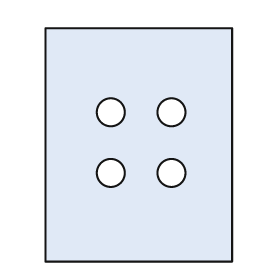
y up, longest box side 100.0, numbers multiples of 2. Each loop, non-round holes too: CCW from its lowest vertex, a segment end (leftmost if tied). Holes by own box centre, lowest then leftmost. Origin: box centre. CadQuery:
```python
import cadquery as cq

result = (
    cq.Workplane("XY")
    .moveTo(-40.0, -50.0)
    .lineTo(40.0, -50.0)
    .lineTo(40.0, 50.0)
    .lineTo(-40.0, 50.0)
    .close()
    .moveTo(-12.0, -12.0)
    .circle(6.0)
    .moveTo(14.0, -12.0)
    .circle(6.0)
    .moveTo(-12.0, 14.0)
    .circle(6.0)
    .moveTo(14.0, 14.0)
    .circle(6.0)
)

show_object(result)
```